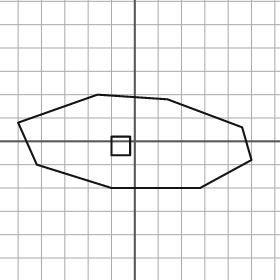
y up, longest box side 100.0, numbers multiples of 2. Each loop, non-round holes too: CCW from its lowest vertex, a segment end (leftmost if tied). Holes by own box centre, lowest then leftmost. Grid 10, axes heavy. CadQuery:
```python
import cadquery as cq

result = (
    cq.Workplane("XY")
    .moveTo(-10.0, -20.0)
    .lineTo(28.0, -20.0)
    .lineTo(50.0, -8.0)
    .lineTo(46.0, 6.0)
    .lineTo(14.0, 18.0)
    .lineTo(-16.0, 20.0)
    .lineTo(-50.0, 8.0)
    .lineTo(-42.0, -10.0)
    .close()
    .moveTo(-10.0, -6.0)
    .lineTo(-2.0, -6.0)
    .lineTo(-2.0, 2.0)
    .lineTo(-10.0, 2.0)
    .close()
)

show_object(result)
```